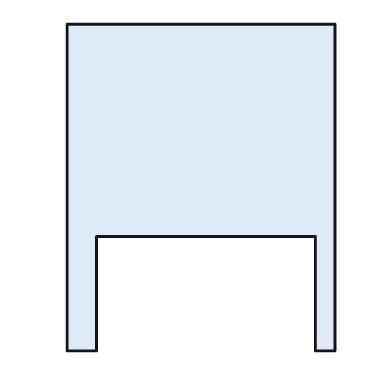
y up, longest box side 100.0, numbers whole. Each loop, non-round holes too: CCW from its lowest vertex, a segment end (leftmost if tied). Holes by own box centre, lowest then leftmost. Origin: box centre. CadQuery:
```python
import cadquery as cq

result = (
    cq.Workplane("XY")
    .moveTo(-41.0, -50.0)
    .lineTo(-32.0, -50.0)
    .lineTo(-32.0, -15.0)
    .lineTo(35.0, -15.0)
    .lineTo(35.0, -50.0)
    .lineTo(41.0, -50.0)
    .lineTo(41.0, 50.0)
    .lineTo(-41.0, 50.0)
    .close()
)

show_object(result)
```